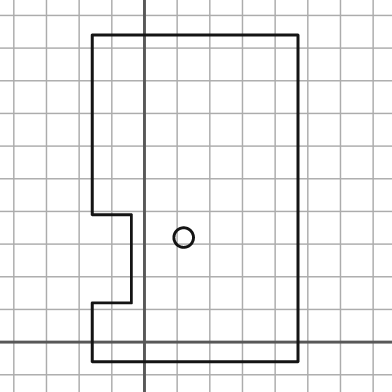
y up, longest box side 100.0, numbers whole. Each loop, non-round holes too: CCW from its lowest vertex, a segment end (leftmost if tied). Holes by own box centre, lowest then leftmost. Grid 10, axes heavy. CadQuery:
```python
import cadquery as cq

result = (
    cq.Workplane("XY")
    .moveTo(-16.0, -6.0)
    .lineTo(47.0, -6.0)
    .lineTo(47.0, 94.0)
    .lineTo(-16.0, 94.0)
    .lineTo(-16.0, 39.0)
    .lineTo(-4.0, 39.0)
    .lineTo(-4.0, 12.0)
    .lineTo(-16.0, 12.0)
    .close()
    .moveTo(12.0, 32.0)
    .circle(3.0)
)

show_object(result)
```